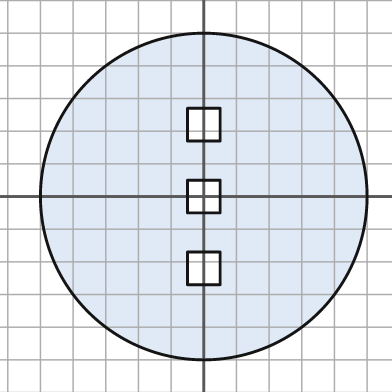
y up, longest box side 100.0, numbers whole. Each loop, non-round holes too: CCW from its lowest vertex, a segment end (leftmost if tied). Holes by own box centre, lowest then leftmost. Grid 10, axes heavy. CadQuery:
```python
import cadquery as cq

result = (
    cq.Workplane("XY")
    .moveTo(0.0, 0.0)
    .circle(50.0)
    .moveTo(-5.0, -27.0)
    .lineTo(5.0, -27.0)
    .lineTo(5.0, -17.0)
    .lineTo(-5.0, -17.0)
    .close()
    .moveTo(-5.0, -5.0)
    .lineTo(5.0, -5.0)
    .lineTo(5.0, 5.0)
    .lineTo(-5.0, 5.0)
    .close()
    .moveTo(-5.0, 17.0)
    .lineTo(5.0, 17.0)
    .lineTo(5.0, 27.0)
    .lineTo(-5.0, 27.0)
    .close()
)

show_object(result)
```